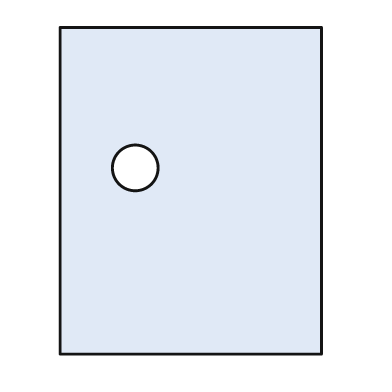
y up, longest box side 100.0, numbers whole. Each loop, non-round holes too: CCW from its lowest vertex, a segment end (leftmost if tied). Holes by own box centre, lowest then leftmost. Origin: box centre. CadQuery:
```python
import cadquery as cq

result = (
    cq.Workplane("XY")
    .moveTo(-40.0, -50.0)
    .lineTo(40.0, -50.0)
    .lineTo(40.0, 50.0)
    .lineTo(-40.0, 50.0)
    .close()
    .moveTo(-17.0, 7.0)
    .circle(7.0)
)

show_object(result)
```